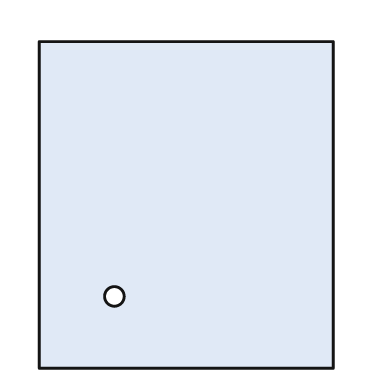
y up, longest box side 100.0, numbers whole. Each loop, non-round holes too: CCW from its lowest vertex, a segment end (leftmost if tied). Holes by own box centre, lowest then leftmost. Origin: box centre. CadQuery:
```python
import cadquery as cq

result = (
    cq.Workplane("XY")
    .moveTo(-45.0, -50.0)
    .lineTo(45.0, -50.0)
    .lineTo(45.0, 50.0)
    .lineTo(-45.0, 50.0)
    .close()
    .moveTo(-22.0, -28.0)
    .circle(3.0)
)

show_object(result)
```